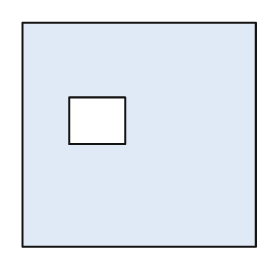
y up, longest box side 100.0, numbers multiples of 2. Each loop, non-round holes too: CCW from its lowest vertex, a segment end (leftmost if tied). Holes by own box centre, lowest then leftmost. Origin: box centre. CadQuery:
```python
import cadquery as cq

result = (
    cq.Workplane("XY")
    .moveTo(-50.0, -48.0)
    .lineTo(50.0, -48.0)
    .lineTo(50.0, 48.0)
    .lineTo(-50.0, 48.0)
    .close()
    .moveTo(-30.0, -4.0)
    .lineTo(-6.0, -4.0)
    .lineTo(-6.0, 16.0)
    .lineTo(-30.0, 16.0)
    .close()
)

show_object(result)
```